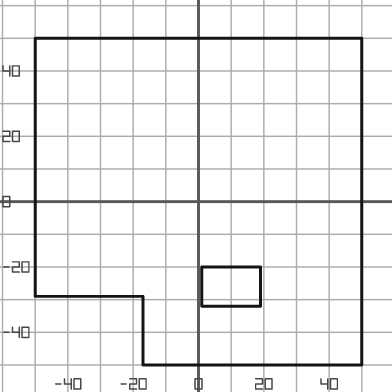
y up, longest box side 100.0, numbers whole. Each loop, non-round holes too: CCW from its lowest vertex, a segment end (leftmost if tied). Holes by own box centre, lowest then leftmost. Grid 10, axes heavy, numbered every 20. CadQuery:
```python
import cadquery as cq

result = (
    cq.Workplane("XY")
    .moveTo(-17.0, -50.0)
    .lineTo(50.0, -50.0)
    .lineTo(50.0, 50.0)
    .lineTo(-50.0, 50.0)
    .lineTo(-50.0, -29.0)
    .lineTo(-17.0, -29.0)
    .close()
    .moveTo(1.0, -32.0)
    .lineTo(19.0, -32.0)
    .lineTo(19.0, -20.0)
    .lineTo(1.0, -20.0)
    .close()
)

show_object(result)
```